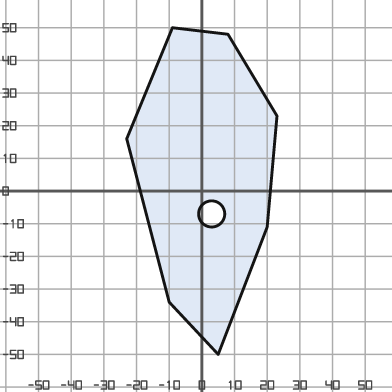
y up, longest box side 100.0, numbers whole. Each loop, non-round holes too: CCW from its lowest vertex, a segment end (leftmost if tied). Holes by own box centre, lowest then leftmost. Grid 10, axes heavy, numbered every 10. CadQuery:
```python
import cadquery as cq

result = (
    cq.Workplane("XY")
    .moveTo(5.0, -50.0)
    .lineTo(20.0, -11.0)
    .lineTo(23.0, 23.0)
    .lineTo(8.0, 48.0)
    .lineTo(-9.0, 50.0)
    .lineTo(-23.0, 16.0)
    .lineTo(-10.0, -34.0)
    .close()
    .moveTo(3.0, -7.0)
    .circle(4.0)
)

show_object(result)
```